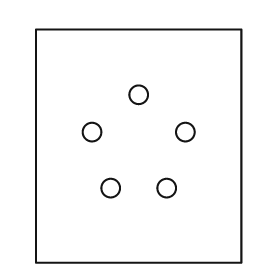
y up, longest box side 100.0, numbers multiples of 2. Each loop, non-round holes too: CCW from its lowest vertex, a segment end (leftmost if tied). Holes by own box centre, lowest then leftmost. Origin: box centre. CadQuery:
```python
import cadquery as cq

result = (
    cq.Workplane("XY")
    .moveTo(-44.0, -50.0)
    .lineTo(44.0, -50.0)
    .lineTo(44.0, 50.0)
    .lineTo(-44.0, 50.0)
    .close()
    .moveTo(-12.0, -18.0)
    .circle(4.0)
    .moveTo(12.0, -18.0)
    .circle(4.0)
    .moveTo(-20.0, 6.0)
    .circle(4.0)
    .moveTo(20.0, 6.0)
    .circle(4.0)
    .moveTo(0.0, 22.0)
    .circle(4.0)
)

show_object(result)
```